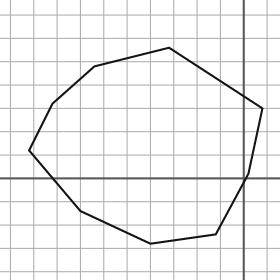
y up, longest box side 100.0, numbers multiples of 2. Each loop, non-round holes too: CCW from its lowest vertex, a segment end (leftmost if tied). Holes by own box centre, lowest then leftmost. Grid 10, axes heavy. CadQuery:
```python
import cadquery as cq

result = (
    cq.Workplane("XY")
    .moveTo(-40.0, -28.0)
    .lineTo(-12.0, -24.0)
    .lineTo(2.0, 2.0)
    .lineTo(8.0, 30.0)
    .lineTo(-32.0, 56.0)
    .lineTo(-64.0, 48.0)
    .lineTo(-82.0, 32.0)
    .lineTo(-92.0, 12.0)
    .lineTo(-70.0, -14.0)
    .close()
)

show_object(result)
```